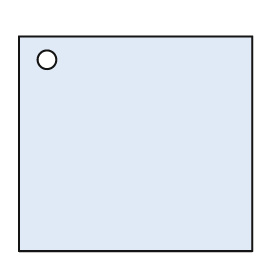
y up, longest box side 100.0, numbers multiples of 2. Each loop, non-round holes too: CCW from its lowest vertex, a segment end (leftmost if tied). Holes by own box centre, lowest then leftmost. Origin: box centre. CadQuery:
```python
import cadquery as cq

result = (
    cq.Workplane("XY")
    .moveTo(-50.0, -46.0)
    .lineTo(50.0, -46.0)
    .lineTo(50.0, 46.0)
    .lineTo(-50.0, 46.0)
    .close()
    .moveTo(-38.0, 36.0)
    .circle(4.0)
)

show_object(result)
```